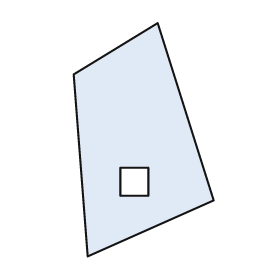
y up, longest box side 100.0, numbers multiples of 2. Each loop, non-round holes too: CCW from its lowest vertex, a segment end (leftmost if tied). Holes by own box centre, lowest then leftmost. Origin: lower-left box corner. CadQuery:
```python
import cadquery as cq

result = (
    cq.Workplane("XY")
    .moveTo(6.0, 0.0)
    .lineTo(60.0, 24.0)
    .lineTo(36.0, 100.0)
    .lineTo(0.0, 78.0)
    .close()
    .moveTo(20.0, 26.0)
    .lineTo(32.0, 26.0)
    .lineTo(32.0, 38.0)
    .lineTo(20.0, 38.0)
    .close()
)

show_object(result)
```